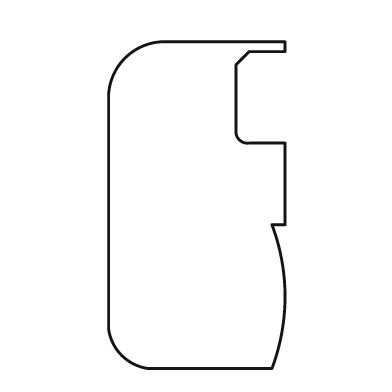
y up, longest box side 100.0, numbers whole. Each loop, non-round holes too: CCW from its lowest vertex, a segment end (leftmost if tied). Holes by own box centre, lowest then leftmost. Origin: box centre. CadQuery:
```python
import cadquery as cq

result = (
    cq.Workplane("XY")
    .moveTo(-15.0, -50.0)
    .lineTo(23.0, -50.0)
    .threePointArc((27.0, -28.0), (23.0, -6.0))
    .lineTo(27.0, -6.0)
    .lineTo(27.0, 19.0)
    .lineTo(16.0, 19.0)
    .threePointArc((13.0, 20.0), (12.0, 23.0))
    .lineTo(12.0, 43.0)
    .lineTo(16.0, 47.0)
    .lineTo(27.0, 47.0)
    .lineTo(27.0, 50.0)
    .lineTo(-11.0, 50.0)
    .threePointArc((-22.0, 45.0), (-27.0, 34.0))
    .lineTo(-27.0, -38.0)
    .threePointArc((-23.0, -46.0), (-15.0, -50.0))
    .close()
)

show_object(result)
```